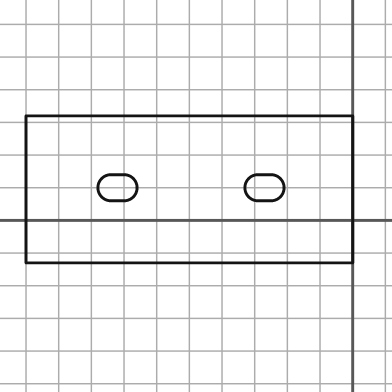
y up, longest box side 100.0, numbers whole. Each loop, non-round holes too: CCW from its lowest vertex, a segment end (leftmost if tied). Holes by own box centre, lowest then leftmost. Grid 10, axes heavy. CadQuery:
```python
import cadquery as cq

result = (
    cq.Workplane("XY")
    .moveTo(-100.0, -13.0)
    .lineTo(0.0, -13.0)
    .lineTo(0.0, 32.0)
    .lineTo(-100.0, 32.0)
    .close()
    .moveTo(-74.0, 6.0)
    .lineTo(-70.0, 6.0)
    .threePointArc((-66.0, 10.0), (-70.0, 14.0))
    .lineTo(-74.0, 14.0)
    .threePointArc((-78.0, 10.0), (-74.0, 6.0))
    .close()
    .moveTo(-29.0, 6.0)
    .lineTo(-25.0, 6.0)
    .threePointArc((-21.0, 10.0), (-25.0, 14.0))
    .lineTo(-29.0, 14.0)
    .threePointArc((-33.0, 10.0), (-29.0, 6.0))
    .close()
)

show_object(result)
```